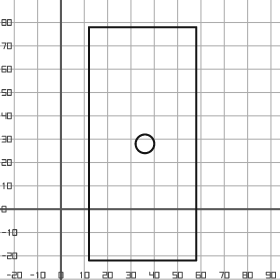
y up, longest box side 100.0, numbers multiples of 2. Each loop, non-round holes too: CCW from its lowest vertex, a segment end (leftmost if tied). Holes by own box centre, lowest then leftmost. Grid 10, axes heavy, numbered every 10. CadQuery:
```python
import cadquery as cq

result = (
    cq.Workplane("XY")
    .moveTo(12.0, -22.0)
    .lineTo(58.0, -22.0)
    .lineTo(58.0, 78.0)
    .lineTo(12.0, 78.0)
    .close()
    .moveTo(36.0, 28.0)
    .circle(4.0)
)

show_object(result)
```